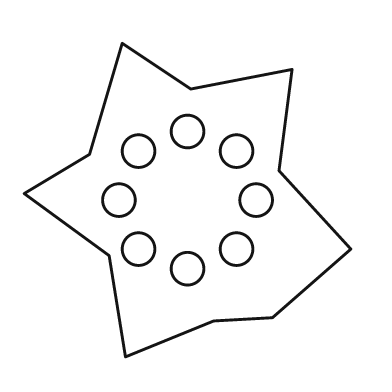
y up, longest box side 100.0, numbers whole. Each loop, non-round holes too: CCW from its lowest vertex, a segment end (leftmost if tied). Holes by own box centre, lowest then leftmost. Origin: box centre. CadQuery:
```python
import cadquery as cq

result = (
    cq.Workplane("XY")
    .moveTo(-19.0, -48.0)
    .lineTo(8.0, -37.0)
    .lineTo(26.0, -36.0)
    .lineTo(50.0, -15.0)
    .lineTo(28.0, 9.0)
    .lineTo(32.0, 40.0)
    .lineTo(1.0, 34.0)
    .lineTo(-20.0, 48.0)
    .lineTo(-30.0, 14.0)
    .lineTo(-50.0, 2.0)
    .lineTo(-24.0, -17.0)
    .close()
    .moveTo(0.0, -21.0)
    .circle(5.0)
    .moveTo(-15.0, -15.0)
    .circle(5.0)
    .moveTo(15.0, -15.0)
    .circle(5.0)
    .moveTo(-21.0, 0.0)
    .circle(5.0)
    .moveTo(21.0, 0.0)
    .circle(5.0)
    .moveTo(-15.0, 15.0)
    .circle(5.0)
    .moveTo(15.0, 15.0)
    .circle(5.0)
    .moveTo(0.0, 21.0)
    .circle(5.0)
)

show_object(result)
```